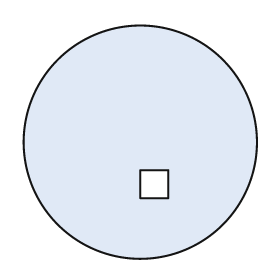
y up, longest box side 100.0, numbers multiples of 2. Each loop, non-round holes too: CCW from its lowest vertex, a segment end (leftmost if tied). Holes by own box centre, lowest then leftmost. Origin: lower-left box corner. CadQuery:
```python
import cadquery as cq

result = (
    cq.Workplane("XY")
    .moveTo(50.0, 50.0)
    .circle(50.0)
    .moveTo(50.0, 26.0)
    .lineTo(62.0, 26.0)
    .lineTo(62.0, 38.0)
    .lineTo(50.0, 38.0)
    .close()
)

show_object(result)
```